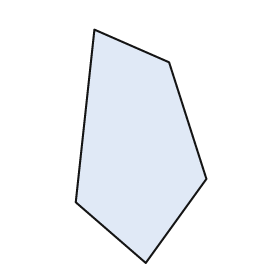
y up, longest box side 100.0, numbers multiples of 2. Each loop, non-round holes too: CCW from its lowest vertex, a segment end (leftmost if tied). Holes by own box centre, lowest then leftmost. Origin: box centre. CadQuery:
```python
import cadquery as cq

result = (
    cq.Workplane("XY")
    .moveTo(2.0, -50.0)
    .lineTo(28.0, -14.0)
    .lineTo(12.0, 36.0)
    .lineTo(-20.0, 50.0)
    .lineTo(-28.0, -24.0)
    .close()
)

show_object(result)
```